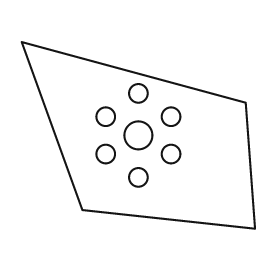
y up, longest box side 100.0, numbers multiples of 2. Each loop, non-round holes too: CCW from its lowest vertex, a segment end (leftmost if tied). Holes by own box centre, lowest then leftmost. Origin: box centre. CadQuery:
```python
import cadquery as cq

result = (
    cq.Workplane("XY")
    .moveTo(50.0, -40.0)
    .lineTo(46.0, 14.0)
    .lineTo(-50.0, 40.0)
    .lineTo(-24.0, -32.0)
    .close()
    .moveTo(0.0, -18.0)
    .circle(4.0)
    .moveTo(-14.0, -8.0)
    .circle(4.0)
    .moveTo(14.0, -8.0)
    .circle(4.0)
    .moveTo(0.0, 0.0)
    .circle(6.0)
    .moveTo(-14.0, 8.0)
    .circle(4.0)
    .moveTo(14.0, 8.0)
    .circle(4.0)
    .moveTo(0.0, 18.0)
    .circle(4.0)
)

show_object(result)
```